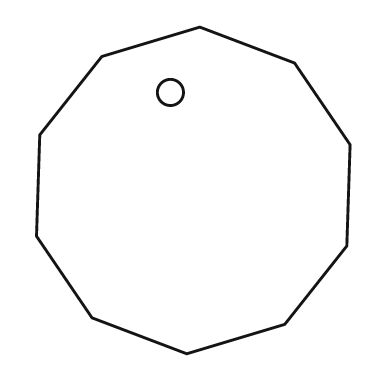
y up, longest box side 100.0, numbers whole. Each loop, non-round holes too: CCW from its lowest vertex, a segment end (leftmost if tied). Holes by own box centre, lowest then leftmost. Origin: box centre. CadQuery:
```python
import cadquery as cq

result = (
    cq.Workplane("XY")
    .moveTo(-2.0, -50.0)
    .lineTo(28.0, -41.0)
    .lineTo(47.0, -17.0)
    .lineTo(48.0, 14.0)
    .lineTo(31.0, 39.0)
    .lineTo(2.0, 50.0)
    .lineTo(-28.0, 41.0)
    .lineTo(-47.0, 17.0)
    .lineTo(-48.0, -14.0)
    .lineTo(-31.0, -39.0)
    .close()
    .moveTo(-7.0, 30.0)
    .circle(4.0)
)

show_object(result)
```